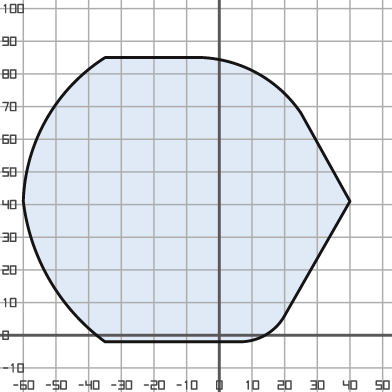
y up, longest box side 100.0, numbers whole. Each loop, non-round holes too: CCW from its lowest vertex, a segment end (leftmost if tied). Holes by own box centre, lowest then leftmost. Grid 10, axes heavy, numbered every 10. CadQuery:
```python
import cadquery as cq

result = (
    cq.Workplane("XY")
    .moveTo(-35.0, -2.0)
    .lineTo(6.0, -2.0)
    .threePointArc((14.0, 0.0), (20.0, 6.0))
    .lineTo(40.0, 41.0)
    .lineTo(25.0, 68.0)
    .threePointArc((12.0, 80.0), (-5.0, 85.0))
    .lineTo(-35.0, 85.0)
    .threePointArc((-53.0, 66.0), (-60.0, 41.0))
    .threePointArc((-52.0, 17.0), (-35.0, -2.0))
    .close()
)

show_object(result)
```